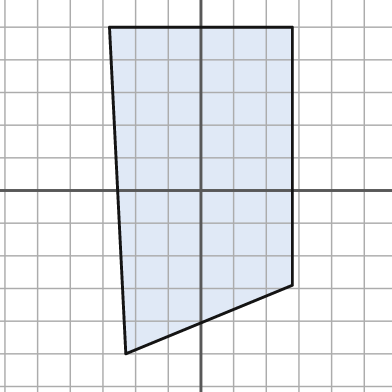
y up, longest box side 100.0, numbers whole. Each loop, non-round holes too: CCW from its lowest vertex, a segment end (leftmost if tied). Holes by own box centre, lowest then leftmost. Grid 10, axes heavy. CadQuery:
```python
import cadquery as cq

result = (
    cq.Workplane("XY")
    .moveTo(-23.0, -50.0)
    .lineTo(28.0, -29.0)
    .lineTo(28.0, 50.0)
    .lineTo(-28.0, 50.0)
    .close()
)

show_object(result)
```